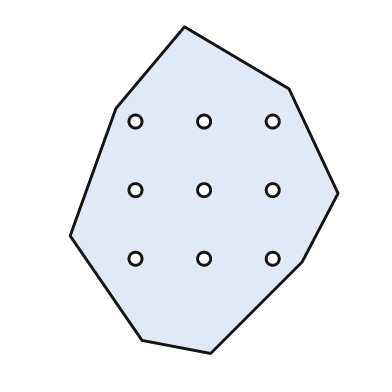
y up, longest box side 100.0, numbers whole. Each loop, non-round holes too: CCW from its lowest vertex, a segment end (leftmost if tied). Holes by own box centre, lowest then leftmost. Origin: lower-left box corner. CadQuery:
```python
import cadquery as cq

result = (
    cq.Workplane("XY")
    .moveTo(43.0, 0.0)
    .lineTo(71.0, 28.0)
    .lineTo(82.0, 49.0)
    .lineTo(67.0, 81.0)
    .lineTo(35.0, 100.0)
    .lineTo(14.0, 75.0)
    .lineTo(0.0, 36.0)
    .lineTo(22.0, 4.0)
    .close()
    .moveTo(20.0, 29.0)
    .circle(2.0)
    .moveTo(41.0, 29.0)
    .circle(2.0)
    .moveTo(62.0, 29.0)
    .circle(2.0)
    .moveTo(20.0, 50.0)
    .circle(2.0)
    .moveTo(41.0, 50.0)
    .circle(2.0)
    .moveTo(62.0, 50.0)
    .circle(2.0)
    .moveTo(20.0, 71.0)
    .circle(2.0)
    .moveTo(41.0, 71.0)
    .circle(2.0)
    .moveTo(62.0, 71.0)
    .circle(2.0)
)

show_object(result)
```